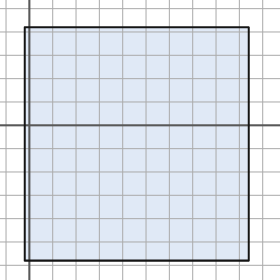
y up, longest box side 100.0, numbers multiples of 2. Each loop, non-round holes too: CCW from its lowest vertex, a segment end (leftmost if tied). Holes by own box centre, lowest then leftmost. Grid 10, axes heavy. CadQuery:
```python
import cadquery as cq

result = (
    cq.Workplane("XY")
    .moveTo(-2.0, -58.0)
    .lineTo(94.0, -58.0)
    .lineTo(94.0, 42.0)
    .lineTo(-2.0, 42.0)
    .close()
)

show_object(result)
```